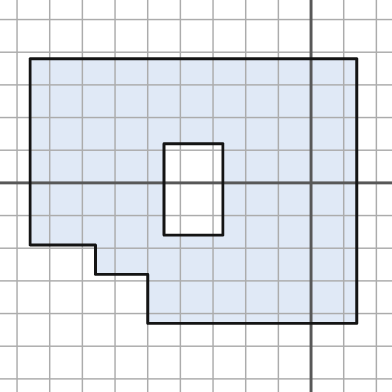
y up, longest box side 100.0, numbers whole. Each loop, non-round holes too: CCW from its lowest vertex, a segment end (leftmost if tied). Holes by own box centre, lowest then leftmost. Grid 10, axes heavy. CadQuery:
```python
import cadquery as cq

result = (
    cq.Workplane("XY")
    .moveTo(-50.0, -43.0)
    .lineTo(14.0, -43.0)
    .lineTo(14.0, 38.0)
    .lineTo(-86.0, 38.0)
    .lineTo(-86.0, -19.0)
    .lineTo(-66.0, -19.0)
    .lineTo(-66.0, -28.0)
    .lineTo(-50.0, -28.0)
    .close()
    .moveTo(-45.0, -16.0)
    .lineTo(-27.0, -16.0)
    .lineTo(-27.0, 12.0)
    .lineTo(-45.0, 12.0)
    .close()
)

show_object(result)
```